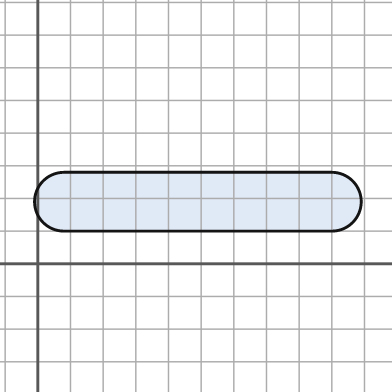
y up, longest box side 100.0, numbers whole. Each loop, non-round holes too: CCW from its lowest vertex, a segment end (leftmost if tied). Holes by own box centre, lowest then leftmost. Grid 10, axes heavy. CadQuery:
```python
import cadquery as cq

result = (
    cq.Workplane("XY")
    .moveTo(8.0, 10.0)
    .lineTo(90.0, 10.0)
    .threePointArc((99.0, 19.0), (90.0, 28.0))
    .lineTo(8.0, 28.0)
    .threePointArc((-1.0, 19.0), (8.0, 10.0))
    .close()
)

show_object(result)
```